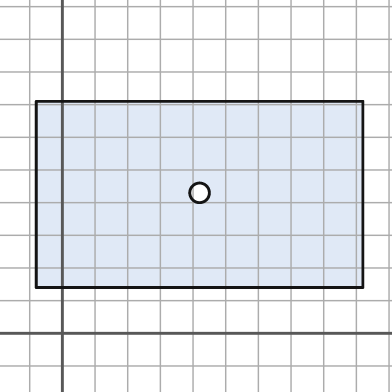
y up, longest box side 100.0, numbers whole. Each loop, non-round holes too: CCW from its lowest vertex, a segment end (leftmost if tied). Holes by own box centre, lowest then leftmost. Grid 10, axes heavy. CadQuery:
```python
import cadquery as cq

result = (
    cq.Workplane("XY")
    .moveTo(-8.0, 14.0)
    .lineTo(92.0, 14.0)
    .lineTo(92.0, 71.0)
    .lineTo(-8.0, 71.0)
    .close()
    .moveTo(42.0, 43.0)
    .circle(3.0)
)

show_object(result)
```